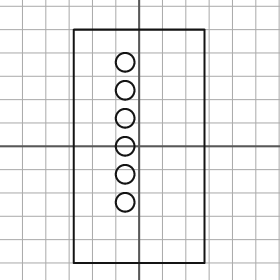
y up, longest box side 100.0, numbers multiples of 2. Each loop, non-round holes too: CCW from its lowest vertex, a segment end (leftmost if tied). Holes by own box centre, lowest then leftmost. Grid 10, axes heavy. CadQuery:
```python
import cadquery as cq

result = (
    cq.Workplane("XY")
    .moveTo(-28.0, -50.0)
    .lineTo(28.0, -50.0)
    .lineTo(28.0, 50.0)
    .lineTo(-28.0, 50.0)
    .close()
    .moveTo(-6.0, -24.0)
    .circle(4.0)
    .moveTo(-6.0, -12.0)
    .circle(4.0)
    .moveTo(-6.0, 0.0)
    .circle(4.0)
    .moveTo(-6.0, 12.0)
    .circle(4.0)
    .moveTo(-6.0, 24.0)
    .circle(4.0)
    .moveTo(-6.0, 36.0)
    .circle(4.0)
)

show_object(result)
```